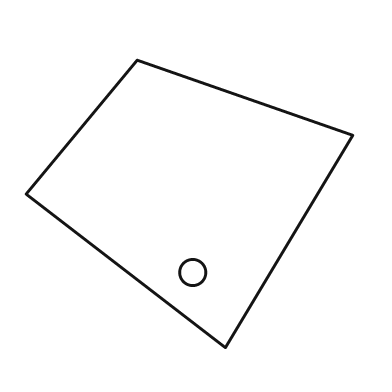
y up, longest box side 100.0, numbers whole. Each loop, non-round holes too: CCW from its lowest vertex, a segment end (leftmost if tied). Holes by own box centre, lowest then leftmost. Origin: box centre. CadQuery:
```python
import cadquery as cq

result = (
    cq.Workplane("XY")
    .moveTo(11.0, -44.0)
    .lineTo(50.0, 21.0)
    .lineTo(-16.0, 44.0)
    .lineTo(-50.0, 3.0)
    .close()
    .moveTo(1.0, -21.0)
    .circle(4.0)
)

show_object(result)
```